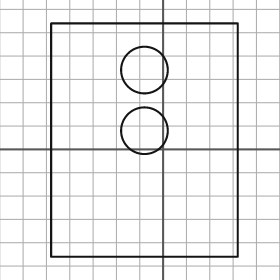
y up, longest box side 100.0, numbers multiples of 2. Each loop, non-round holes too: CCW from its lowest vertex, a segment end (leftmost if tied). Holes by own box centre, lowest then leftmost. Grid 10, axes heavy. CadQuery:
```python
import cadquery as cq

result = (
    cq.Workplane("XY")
    .moveTo(-48.0, -46.0)
    .lineTo(32.0, -46.0)
    .lineTo(32.0, 54.0)
    .lineTo(-48.0, 54.0)
    .close()
    .moveTo(-8.0, 8.0)
    .circle(10.0)
    .moveTo(-8.0, 34.0)
    .circle(10.0)
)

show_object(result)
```